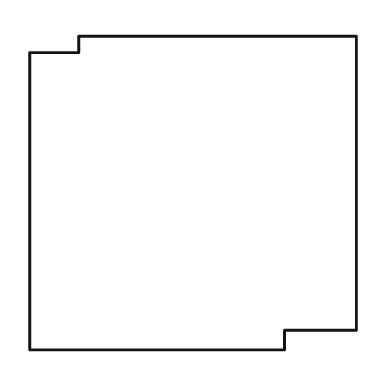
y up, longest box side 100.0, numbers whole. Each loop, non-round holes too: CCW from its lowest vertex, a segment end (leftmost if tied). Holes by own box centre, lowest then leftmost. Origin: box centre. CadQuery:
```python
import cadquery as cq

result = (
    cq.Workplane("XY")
    .moveTo(-50.0, -48.0)
    .lineTo(28.0, -48.0)
    .lineTo(28.0, -42.0)
    .lineTo(50.0, -42.0)
    .lineTo(50.0, 48.0)
    .lineTo(-35.0, 48.0)
    .lineTo(-35.0, 43.0)
    .lineTo(-50.0, 43.0)
    .close()
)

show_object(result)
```